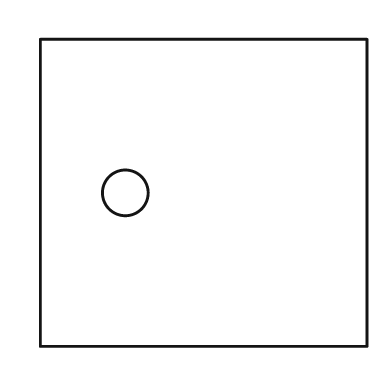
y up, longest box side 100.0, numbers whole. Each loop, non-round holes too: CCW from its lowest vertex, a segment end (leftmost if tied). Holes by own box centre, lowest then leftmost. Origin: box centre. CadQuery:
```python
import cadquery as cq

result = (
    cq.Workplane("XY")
    .moveTo(-50.0, -47.0)
    .lineTo(50.0, -47.0)
    .lineTo(50.0, 47.0)
    .lineTo(-50.0, 47.0)
    .close()
    .moveTo(-24.0, 0.0)
    .circle(7.0)
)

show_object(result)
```